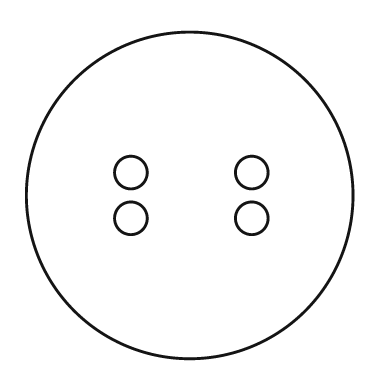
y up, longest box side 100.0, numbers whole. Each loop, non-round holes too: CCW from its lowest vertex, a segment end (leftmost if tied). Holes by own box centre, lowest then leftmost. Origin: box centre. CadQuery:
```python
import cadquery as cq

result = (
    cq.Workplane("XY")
    .moveTo(0.0, 0.0)
    .circle(50.0)
    .moveTo(-18.0, -7.0)
    .circle(5.0)
    .moveTo(19.0, -7.0)
    .circle(5.0)
    .moveTo(-18.0, 7.0)
    .circle(5.0)
    .moveTo(19.0, 7.0)
    .circle(5.0)
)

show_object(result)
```